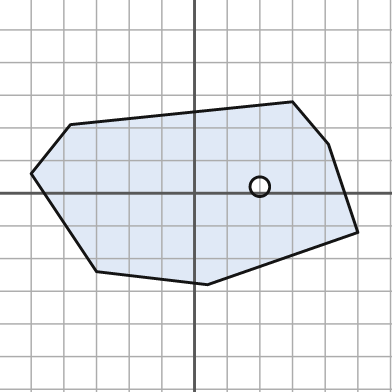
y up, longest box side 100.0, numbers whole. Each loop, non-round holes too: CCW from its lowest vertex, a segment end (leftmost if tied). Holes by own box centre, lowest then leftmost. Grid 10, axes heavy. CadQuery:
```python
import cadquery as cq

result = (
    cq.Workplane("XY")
    .moveTo(4.0, -28.0)
    .lineTo(50.0, -12.0)
    .lineTo(41.0, 15.0)
    .lineTo(30.0, 28.0)
    .lineTo(-38.0, 21.0)
    .lineTo(-50.0, 6.0)
    .lineTo(-30.0, -24.0)
    .close()
    .moveTo(20.0, 2.0)
    .circle(3.0)
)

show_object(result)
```